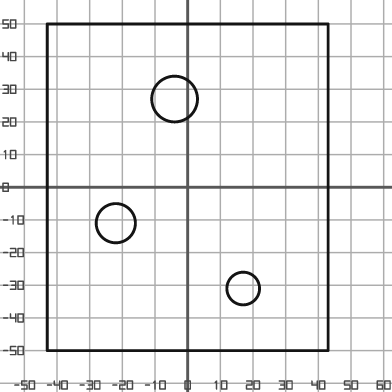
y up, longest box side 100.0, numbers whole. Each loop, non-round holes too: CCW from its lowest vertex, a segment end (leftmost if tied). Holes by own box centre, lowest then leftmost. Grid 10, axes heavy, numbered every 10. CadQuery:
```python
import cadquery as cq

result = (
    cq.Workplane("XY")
    .moveTo(-43.0, -50.0)
    .lineTo(43.0, -50.0)
    .lineTo(43.0, 50.0)
    .lineTo(-43.0, 50.0)
    .close()
    .moveTo(17.0, -31.0)
    .circle(5.0)
    .moveTo(-22.0, -11.0)
    .circle(6.0)
    .moveTo(-4.0, 27.0)
    .circle(7.0)
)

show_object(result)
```